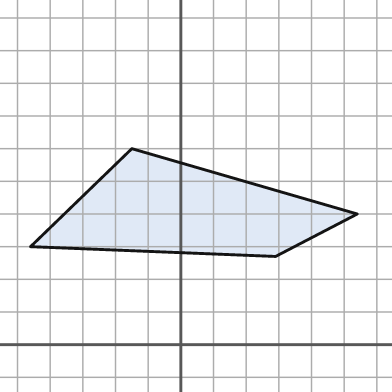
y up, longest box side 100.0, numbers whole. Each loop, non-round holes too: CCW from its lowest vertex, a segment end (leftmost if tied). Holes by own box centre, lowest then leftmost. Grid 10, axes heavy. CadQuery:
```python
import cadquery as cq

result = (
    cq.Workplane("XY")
    .moveTo(29.0, 27.0)
    .lineTo(54.0, 40.0)
    .lineTo(-15.0, 60.0)
    .lineTo(-46.0, 30.0)
    .close()
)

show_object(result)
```